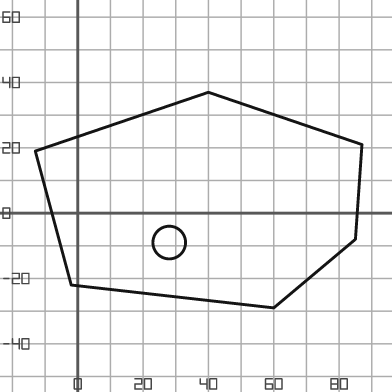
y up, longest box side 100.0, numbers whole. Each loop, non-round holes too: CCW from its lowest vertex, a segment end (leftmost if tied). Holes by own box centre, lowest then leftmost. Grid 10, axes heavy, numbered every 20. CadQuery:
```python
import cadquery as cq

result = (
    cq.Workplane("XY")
    .moveTo(60.0, -29.0)
    .lineTo(85.0, -8.0)
    .lineTo(87.0, 21.0)
    .lineTo(40.0, 37.0)
    .lineTo(-13.0, 19.0)
    .lineTo(-2.0, -22.0)
    .close()
    .moveTo(28.0, -9.0)
    .circle(5.0)
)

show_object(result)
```